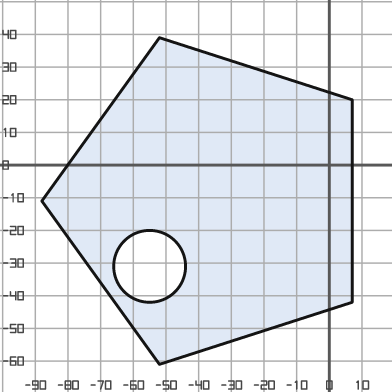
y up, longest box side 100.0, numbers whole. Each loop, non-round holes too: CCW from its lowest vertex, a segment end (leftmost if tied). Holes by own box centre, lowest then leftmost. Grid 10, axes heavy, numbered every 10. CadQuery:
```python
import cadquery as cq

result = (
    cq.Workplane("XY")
    .moveTo(-52.0, -61.0)
    .lineTo(7.0, -42.0)
    .lineTo(7.0, 20.0)
    .lineTo(-52.0, 39.0)
    .lineTo(-88.0, -11.0)
    .close()
    .moveTo(-55.0, -31.0)
    .circle(11.0)
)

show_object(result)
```